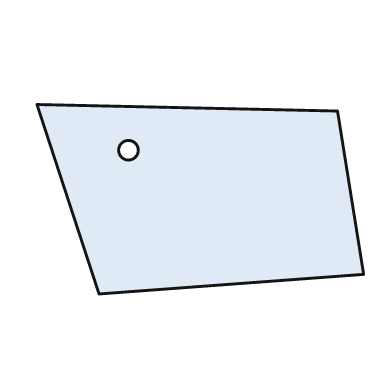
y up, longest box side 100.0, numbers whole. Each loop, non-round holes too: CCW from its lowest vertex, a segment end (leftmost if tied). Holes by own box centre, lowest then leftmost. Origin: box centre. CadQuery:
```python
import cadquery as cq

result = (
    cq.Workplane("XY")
    .moveTo(-31.0, -29.0)
    .lineTo(50.0, -23.0)
    .lineTo(42.0, 27.0)
    .lineTo(-50.0, 29.0)
    .close()
    .moveTo(-22.0, 15.0)
    .circle(3.0)
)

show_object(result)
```